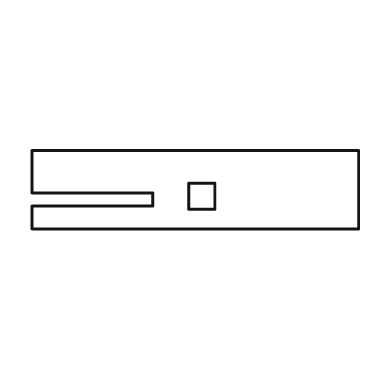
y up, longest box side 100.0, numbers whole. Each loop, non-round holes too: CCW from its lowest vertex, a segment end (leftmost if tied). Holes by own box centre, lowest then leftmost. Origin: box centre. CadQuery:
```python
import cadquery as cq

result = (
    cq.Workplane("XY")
    .moveTo(-50.0, -12.0)
    .lineTo(50.0, -12.0)
    .lineTo(50.0, 12.0)
    .lineTo(-50.0, 12.0)
    .lineTo(-50.0, -1.0)
    .lineTo(-13.0, -1.0)
    .lineTo(-13.0, -5.0)
    .lineTo(-50.0, -5.0)
    .close()
    .moveTo(-2.0, -6.0)
    .lineTo(6.0, -6.0)
    .lineTo(6.0, 2.0)
    .lineTo(-2.0, 2.0)
    .close()
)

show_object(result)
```